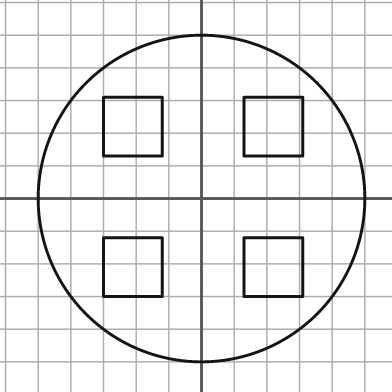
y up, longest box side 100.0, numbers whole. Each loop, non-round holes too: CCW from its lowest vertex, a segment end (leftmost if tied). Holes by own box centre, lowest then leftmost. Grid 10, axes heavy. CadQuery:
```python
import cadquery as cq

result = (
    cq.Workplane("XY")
    .moveTo(0.0, 0.0)
    .circle(50.0)
    .moveTo(-30.0, -30.0)
    .lineTo(-12.0, -30.0)
    .lineTo(-12.0, -12.0)
    .lineTo(-30.0, -12.0)
    .close()
    .moveTo(13.0, -30.0)
    .lineTo(31.0, -30.0)
    .lineTo(31.0, -12.0)
    .lineTo(13.0, -12.0)
    .close()
    .moveTo(-30.0, 13.0)
    .lineTo(-12.0, 13.0)
    .lineTo(-12.0, 31.0)
    .lineTo(-30.0, 31.0)
    .close()
    .moveTo(13.0, 13.0)
    .lineTo(31.0, 13.0)
    .lineTo(31.0, 31.0)
    .lineTo(13.0, 31.0)
    .close()
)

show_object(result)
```